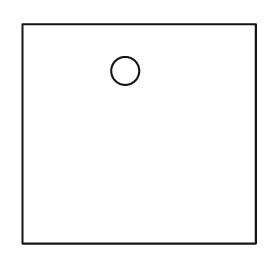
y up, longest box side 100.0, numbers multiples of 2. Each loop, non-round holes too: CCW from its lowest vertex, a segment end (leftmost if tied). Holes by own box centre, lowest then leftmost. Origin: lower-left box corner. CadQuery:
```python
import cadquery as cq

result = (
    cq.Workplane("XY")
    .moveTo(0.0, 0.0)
    .lineTo(100.0, 0.0)
    .lineTo(100.0, 94.0)
    .lineTo(0.0, 94.0)
    .close()
    .moveTo(44.0, 74.0)
    .circle(6.0)
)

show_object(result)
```